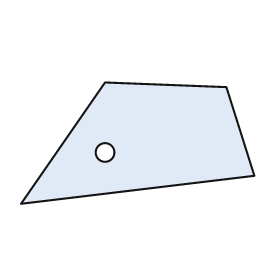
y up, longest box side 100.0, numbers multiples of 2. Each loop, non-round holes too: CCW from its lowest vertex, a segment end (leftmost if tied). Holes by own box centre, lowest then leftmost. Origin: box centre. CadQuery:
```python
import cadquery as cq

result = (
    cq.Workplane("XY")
    .moveTo(-50.0, -26.0)
    .lineTo(50.0, -14.0)
    .lineTo(38.0, 24.0)
    .lineTo(-14.0, 26.0)
    .close()
    .moveTo(-14.0, -4.0)
    .circle(4.0)
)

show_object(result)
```